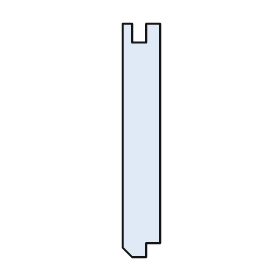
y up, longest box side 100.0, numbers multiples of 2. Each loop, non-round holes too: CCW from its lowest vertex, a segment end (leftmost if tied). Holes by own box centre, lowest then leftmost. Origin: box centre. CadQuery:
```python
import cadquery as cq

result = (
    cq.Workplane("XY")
    .moveTo(-4.0, -50.0)
    .lineTo(2.0, -50.0)
    .lineTo(2.0, -44.0)
    .lineTo(8.0, -44.0)
    .lineTo(8.0, 50.0)
    .lineTo(2.0, 50.0)
    .lineTo(2.0, 42.0)
    .lineTo(-4.0, 42.0)
    .lineTo(-4.0, 50.0)
    .lineTo(-8.0, 50.0)
    .lineTo(-8.0, -46.0)
    .close()
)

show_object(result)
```